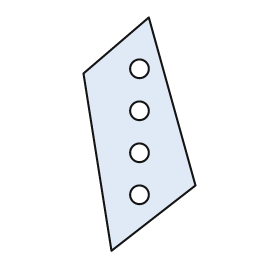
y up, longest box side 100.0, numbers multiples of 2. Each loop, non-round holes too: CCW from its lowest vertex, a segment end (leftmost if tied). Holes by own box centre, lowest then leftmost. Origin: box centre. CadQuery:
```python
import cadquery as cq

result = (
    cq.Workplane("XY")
    .moveTo(-12.0, -50.0)
    .lineTo(24.0, -22.0)
    .lineTo(4.0, 50.0)
    .lineTo(-24.0, 26.0)
    .close()
    .moveTo(0.0, -26.0)
    .circle(4.0)
    .moveTo(0.0, -8.0)
    .circle(4.0)
    .moveTo(0.0, 10.0)
    .circle(4.0)
    .moveTo(0.0, 28.0)
    .circle(4.0)
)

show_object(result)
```